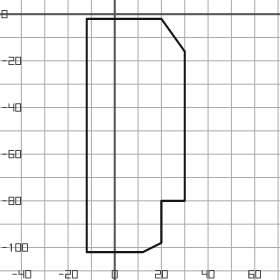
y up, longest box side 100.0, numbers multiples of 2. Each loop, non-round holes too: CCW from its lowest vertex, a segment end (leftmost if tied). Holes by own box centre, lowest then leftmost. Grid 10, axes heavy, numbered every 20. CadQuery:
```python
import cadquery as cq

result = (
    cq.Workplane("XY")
    .moveTo(-12.0, -102.0)
    .lineTo(12.0, -102.0)
    .lineTo(20.0, -98.0)
    .lineTo(20.0, -80.0)
    .lineTo(30.0, -80.0)
    .lineTo(30.0, -16.0)
    .lineTo(20.0, -2.0)
    .lineTo(-12.0, -2.0)
    .close()
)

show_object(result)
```